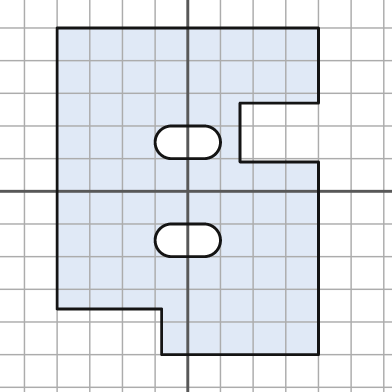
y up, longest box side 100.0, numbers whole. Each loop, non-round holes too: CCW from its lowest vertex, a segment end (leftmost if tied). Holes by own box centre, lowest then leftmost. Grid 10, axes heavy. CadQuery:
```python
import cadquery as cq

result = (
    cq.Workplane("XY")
    .moveTo(-8.0, -50.0)
    .lineTo(40.0, -50.0)
    .lineTo(40.0, 9.0)
    .lineTo(16.0, 9.0)
    .lineTo(16.0, 27.0)
    .lineTo(40.0, 27.0)
    .lineTo(40.0, 50.0)
    .lineTo(-40.0, 50.0)
    .lineTo(-40.0, -36.0)
    .lineTo(-8.0, -36.0)
    .close()
    .moveTo(-5.0, -20.0)
    .lineTo(5.0, -20.0)
    .threePointArc((10.0, -15.0), (5.0, -10.0))
    .lineTo(-5.0, -10.0)
    .threePointArc((-10.0, -15.0), (-5.0, -20.0))
    .close()
    .moveTo(-5.0, 10.0)
    .lineTo(5.0, 10.0)
    .threePointArc((10.0, 15.0), (5.0, 20.0))
    .lineTo(-5.0, 20.0)
    .threePointArc((-10.0, 15.0), (-5.0, 10.0))
    .close()
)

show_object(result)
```